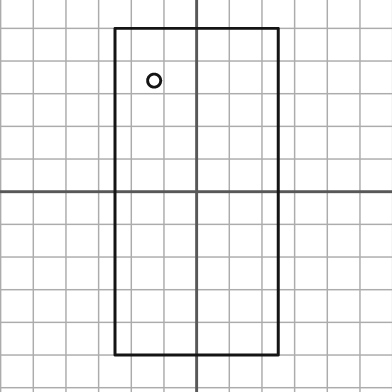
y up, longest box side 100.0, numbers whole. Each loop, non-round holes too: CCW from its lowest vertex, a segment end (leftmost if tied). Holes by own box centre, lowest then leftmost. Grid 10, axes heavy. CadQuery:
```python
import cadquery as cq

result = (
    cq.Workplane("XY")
    .moveTo(-25.0, -50.0)
    .lineTo(25.0, -50.0)
    .lineTo(25.0, 50.0)
    .lineTo(-25.0, 50.0)
    .close()
    .moveTo(-13.0, 34.0)
    .circle(2.0)
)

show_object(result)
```